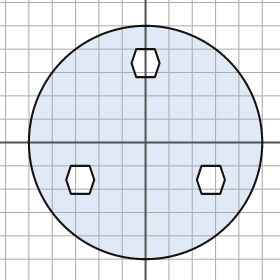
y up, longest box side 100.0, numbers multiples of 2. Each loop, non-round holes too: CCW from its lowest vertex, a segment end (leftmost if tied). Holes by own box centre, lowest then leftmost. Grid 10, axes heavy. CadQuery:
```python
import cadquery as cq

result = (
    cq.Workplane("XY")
    .moveTo(0.0, 0.0)
    .circle(50.0)
    .moveTo(-32.0, -22.0)
    .lineTo(-24.0, -22.0)
    .lineTo(-22.0, -16.0)
    .lineTo(-24.0, -10.0)
    .lineTo(-32.0, -10.0)
    .lineTo(-34.0, -16.0)
    .close()
    .moveTo(24.0, -22.0)
    .lineTo(32.0, -22.0)
    .lineTo(34.0, -16.0)
    .lineTo(32.0, -10.0)
    .lineTo(24.0, -10.0)
    .lineTo(22.0, -16.0)
    .close()
    .moveTo(-4.0, 28.0)
    .lineTo(4.0, 28.0)
    .lineTo(6.0, 34.0)
    .lineTo(4.0, 40.0)
    .lineTo(-4.0, 40.0)
    .lineTo(-6.0, 34.0)
    .close()
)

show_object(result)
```